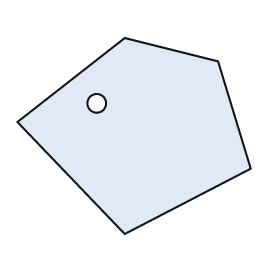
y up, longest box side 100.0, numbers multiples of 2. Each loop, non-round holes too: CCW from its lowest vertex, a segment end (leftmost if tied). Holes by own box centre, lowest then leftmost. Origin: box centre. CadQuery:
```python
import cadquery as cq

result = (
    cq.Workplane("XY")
    .moveTo(-4.0, -42.0)
    .lineTo(50.0, -14.0)
    .lineTo(36.0, 32.0)
    .lineTo(-4.0, 42.0)
    .lineTo(-50.0, 6.0)
    .close()
    .moveTo(-16.0, 14.0)
    .circle(4.0)
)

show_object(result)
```